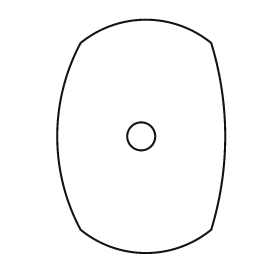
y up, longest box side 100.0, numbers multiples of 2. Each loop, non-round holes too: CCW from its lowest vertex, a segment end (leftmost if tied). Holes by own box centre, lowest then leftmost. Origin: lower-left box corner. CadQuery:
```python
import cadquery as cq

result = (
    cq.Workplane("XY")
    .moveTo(10.0, 10.0)
    .threePointArc((38.0, 0.0), (66.0, 10.0))
    .threePointArc((72.0, 50.0), (66.0, 90.0))
    .threePointArc((38.0, 100.0), (10.0, 90.0))
    .threePointArc((0.0, 50.0), (10.0, 10.0))
    .close()
    .moveTo(36.0, 50.0)
    .circle(6.0)
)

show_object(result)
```